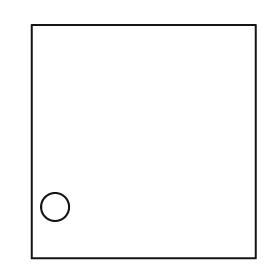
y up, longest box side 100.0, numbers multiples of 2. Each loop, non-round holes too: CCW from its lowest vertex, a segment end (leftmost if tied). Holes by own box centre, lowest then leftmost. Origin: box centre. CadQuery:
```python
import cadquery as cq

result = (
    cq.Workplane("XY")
    .moveTo(-48.0, -50.0)
    .lineTo(48.0, -50.0)
    .lineTo(48.0, 50.0)
    .lineTo(-48.0, 50.0)
    .close()
    .moveTo(-38.0, -28.0)
    .circle(6.0)
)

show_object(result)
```